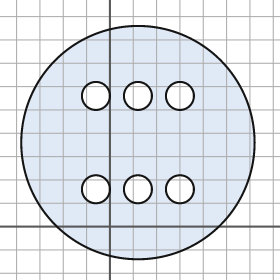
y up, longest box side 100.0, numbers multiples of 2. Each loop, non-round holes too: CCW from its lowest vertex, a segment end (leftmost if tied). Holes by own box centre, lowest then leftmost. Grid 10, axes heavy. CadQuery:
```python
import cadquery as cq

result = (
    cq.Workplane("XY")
    .moveTo(12.0, 36.0)
    .circle(50.0)
    .moveTo(-6.0, 16.0)
    .circle(6.0)
    .moveTo(12.0, 16.0)
    .circle(6.0)
    .moveTo(30.0, 16.0)
    .circle(6.0)
    .moveTo(-6.0, 56.0)
    .circle(6.0)
    .moveTo(12.0, 56.0)
    .circle(6.0)
    .moveTo(30.0, 56.0)
    .circle(6.0)
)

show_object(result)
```